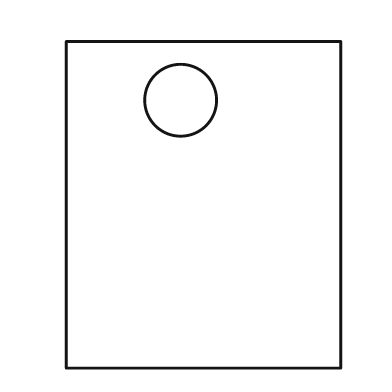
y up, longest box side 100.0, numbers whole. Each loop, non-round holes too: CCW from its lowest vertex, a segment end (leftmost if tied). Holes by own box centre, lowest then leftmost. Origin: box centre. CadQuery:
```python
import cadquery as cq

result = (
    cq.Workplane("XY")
    .moveTo(-42.0, -50.0)
    .lineTo(42.0, -50.0)
    .lineTo(42.0, 50.0)
    .lineTo(-42.0, 50.0)
    .close()
    .moveTo(-7.0, 32.0)
    .circle(11.0)
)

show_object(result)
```